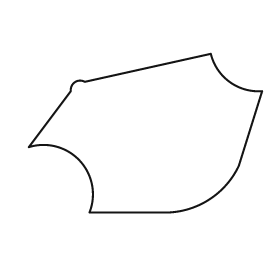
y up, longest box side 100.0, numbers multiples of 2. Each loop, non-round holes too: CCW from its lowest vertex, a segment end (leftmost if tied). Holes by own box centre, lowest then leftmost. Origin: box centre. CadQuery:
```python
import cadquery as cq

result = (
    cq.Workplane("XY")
    .moveTo(-24.0, -34.0)
    .lineTo(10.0, -34.0)
    .threePointArc((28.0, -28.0), (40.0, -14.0))
    .lineTo(50.0, 18.0)
    .threePointArc((36.0, 22.0), (28.0, 34.0))
    .lineTo(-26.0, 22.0)
    .threePointArc((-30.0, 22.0), (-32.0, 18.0))
    .lineTo(-50.0, -6.0)
    .threePointArc((-28.0, -12.0), (-24.0, -34.0))
    .close()
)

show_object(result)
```